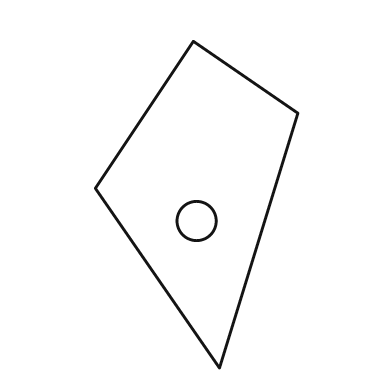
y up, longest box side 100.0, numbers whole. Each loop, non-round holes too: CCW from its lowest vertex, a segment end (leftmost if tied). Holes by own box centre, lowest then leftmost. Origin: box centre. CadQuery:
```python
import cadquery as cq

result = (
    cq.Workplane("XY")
    .moveTo(7.0, -50.0)
    .lineTo(31.0, 28.0)
    .lineTo(-1.0, 50.0)
    .lineTo(-31.0, 5.0)
    .close()
    .moveTo(0.0, -5.0)
    .circle(6.0)
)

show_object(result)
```